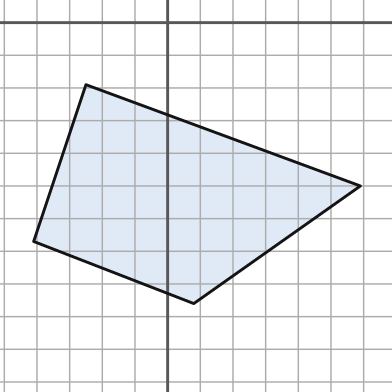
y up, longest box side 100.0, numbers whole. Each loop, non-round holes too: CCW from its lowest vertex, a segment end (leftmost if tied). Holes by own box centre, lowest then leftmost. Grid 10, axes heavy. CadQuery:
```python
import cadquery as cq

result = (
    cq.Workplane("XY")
    .moveTo(8.0, -86.0)
    .lineTo(59.0, -50.0)
    .lineTo(-25.0, -19.0)
    .lineTo(-41.0, -67.0)
    .close()
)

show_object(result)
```